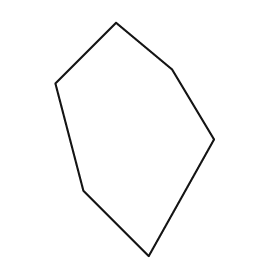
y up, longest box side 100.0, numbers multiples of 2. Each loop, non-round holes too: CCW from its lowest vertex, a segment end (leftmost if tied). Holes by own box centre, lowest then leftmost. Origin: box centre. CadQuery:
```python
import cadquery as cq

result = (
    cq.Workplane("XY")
    .moveTo(6.0, -50.0)
    .lineTo(34.0, 0.0)
    .lineTo(16.0, 30.0)
    .lineTo(-8.0, 50.0)
    .lineTo(-34.0, 24.0)
    .lineTo(-22.0, -22.0)
    .close()
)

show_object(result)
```